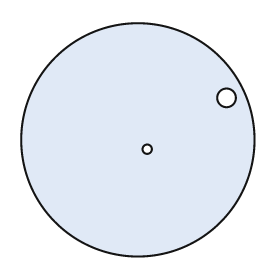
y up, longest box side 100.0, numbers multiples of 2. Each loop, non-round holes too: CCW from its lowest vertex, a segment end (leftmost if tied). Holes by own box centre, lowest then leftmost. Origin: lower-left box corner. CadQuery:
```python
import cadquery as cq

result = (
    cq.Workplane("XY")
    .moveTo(50.0, 50.0)
    .circle(50.0)
    .moveTo(54.0, 46.0)
    .circle(2.0)
    .moveTo(88.0, 68.0)
    .circle(4.0)
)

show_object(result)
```